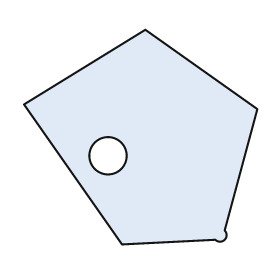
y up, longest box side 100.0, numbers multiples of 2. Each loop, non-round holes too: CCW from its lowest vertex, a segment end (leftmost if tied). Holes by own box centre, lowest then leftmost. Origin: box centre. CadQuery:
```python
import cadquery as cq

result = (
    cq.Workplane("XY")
    .moveTo(-8.0, -46.0)
    .lineTo(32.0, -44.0)
    .threePointArc((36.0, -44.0), (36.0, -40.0))
    .lineTo(50.0, 12.0)
    .lineTo(2.0, 46.0)
    .lineTo(-50.0, 14.0)
    .close()
    .moveTo(-14.0, -8.0)
    .circle(8.0)
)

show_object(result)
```